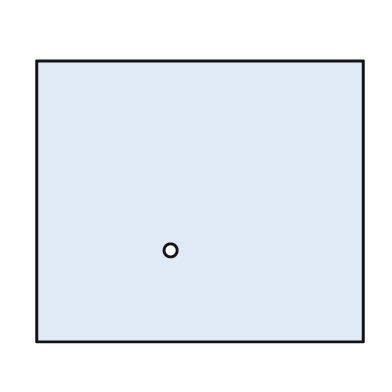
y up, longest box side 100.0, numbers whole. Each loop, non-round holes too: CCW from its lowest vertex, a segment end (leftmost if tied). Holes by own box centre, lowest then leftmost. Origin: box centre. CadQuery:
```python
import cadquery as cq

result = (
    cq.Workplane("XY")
    .moveTo(-50.0, -43.0)
    .lineTo(50.0, -43.0)
    .lineTo(50.0, 43.0)
    .lineTo(-50.0, 43.0)
    .close()
    .moveTo(-9.0, -15.0)
    .circle(2.0)
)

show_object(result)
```